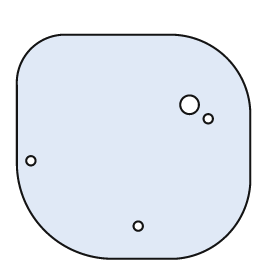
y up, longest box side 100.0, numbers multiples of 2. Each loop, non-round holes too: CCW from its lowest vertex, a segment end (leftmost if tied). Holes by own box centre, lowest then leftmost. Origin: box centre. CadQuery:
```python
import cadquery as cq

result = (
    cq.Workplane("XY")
    .moveTo(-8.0, -48.0)
    .lineTo(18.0, -48.0)
    .threePointArc((40.0, -38.0), (50.0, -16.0))
    .lineTo(50.0, 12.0)
    .threePointArc((40.0, 38.0), (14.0, 48.0))
    .lineTo(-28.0, 48.0)
    .threePointArc((-44.0, 42.0), (-50.0, 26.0))
    .lineTo(-50.0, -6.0)
    .threePointArc((-38.0, -36.0), (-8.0, -48.0))
    .close()
    .moveTo(2.0, -34.0)
    .circle(2.0)
    .moveTo(-44.0, -6.0)
    .circle(2.0)
    .moveTo(32.0, 12.0)
    .circle(2.0)
    .moveTo(24.0, 18.0)
    .circle(4.0)
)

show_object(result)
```